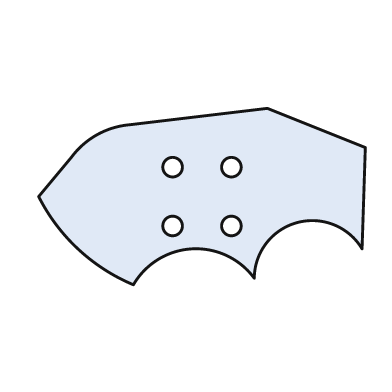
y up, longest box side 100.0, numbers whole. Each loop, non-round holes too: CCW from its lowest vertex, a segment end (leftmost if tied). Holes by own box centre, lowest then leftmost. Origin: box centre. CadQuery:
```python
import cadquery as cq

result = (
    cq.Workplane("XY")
    .moveTo(-21.0, -27.0)
    .threePointArc((-3.0, -16.0), (16.0, -25.0))
    .threePointArc((29.0, -8.0), (49.0, -16.0))
    .lineTo(50.0, 15.0)
    .lineTo(20.0, 27.0)
    .lineTo(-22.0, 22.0)
    .threePointArc((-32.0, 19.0), (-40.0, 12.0))
    .lineTo(-50.0, 0.0)
    .threePointArc((-38.0, -16.0), (-21.0, -27.0))
    .close()
    .moveTo(-9.0, -9.0)
    .circle(3.0)
    .moveTo(9.0, -9.0)
    .circle(3.0)
    .moveTo(-9.0, 9.0)
    .circle(3.0)
    .moveTo(9.0, 9.0)
    .circle(3.0)
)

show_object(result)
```